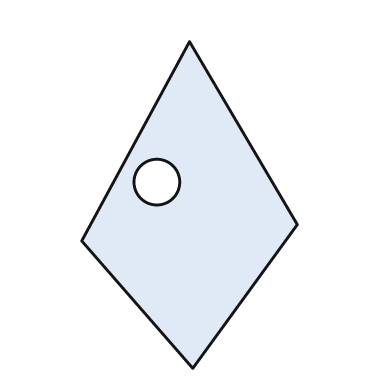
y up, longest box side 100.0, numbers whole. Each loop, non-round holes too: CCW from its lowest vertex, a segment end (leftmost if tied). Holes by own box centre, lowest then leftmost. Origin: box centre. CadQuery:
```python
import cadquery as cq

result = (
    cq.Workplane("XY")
    .moveTo(1.0, -50.0)
    .lineTo(33.0, -6.0)
    .lineTo(0.0, 50.0)
    .lineTo(-33.0, -11.0)
    .close()
    .moveTo(-10.0, 7.0)
    .circle(7.0)
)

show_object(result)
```